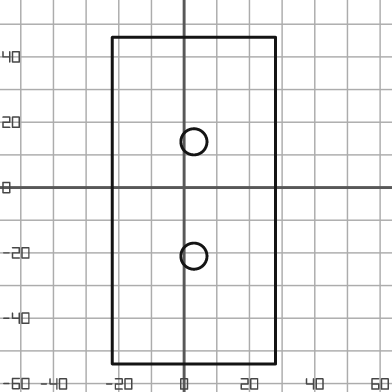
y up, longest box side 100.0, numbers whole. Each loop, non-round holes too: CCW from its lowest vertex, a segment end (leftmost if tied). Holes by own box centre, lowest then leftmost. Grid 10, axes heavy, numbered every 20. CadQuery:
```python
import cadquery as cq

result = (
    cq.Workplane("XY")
    .moveTo(-22.0, -54.0)
    .lineTo(28.0, -54.0)
    .lineTo(28.0, 46.0)
    .lineTo(-22.0, 46.0)
    .close()
    .moveTo(3.0, -21.0)
    .circle(4.0)
    .moveTo(3.0, 14.0)
    .circle(4.0)
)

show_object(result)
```